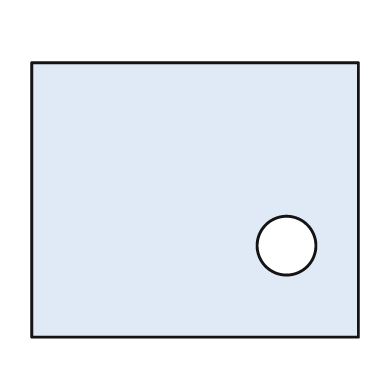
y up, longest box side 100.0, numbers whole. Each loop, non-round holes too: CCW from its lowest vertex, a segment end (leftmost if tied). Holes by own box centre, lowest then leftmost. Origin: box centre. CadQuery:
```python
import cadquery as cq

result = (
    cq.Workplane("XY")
    .moveTo(-50.0, -42.0)
    .lineTo(50.0, -42.0)
    .lineTo(50.0, 42.0)
    .lineTo(-50.0, 42.0)
    .close()
    .moveTo(28.0, -14.0)
    .circle(9.0)
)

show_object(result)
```